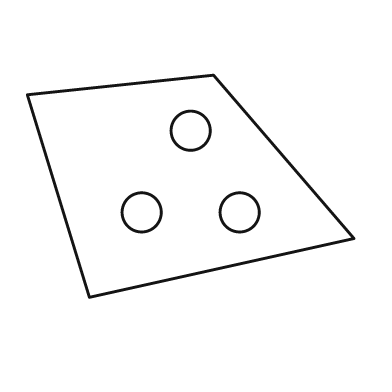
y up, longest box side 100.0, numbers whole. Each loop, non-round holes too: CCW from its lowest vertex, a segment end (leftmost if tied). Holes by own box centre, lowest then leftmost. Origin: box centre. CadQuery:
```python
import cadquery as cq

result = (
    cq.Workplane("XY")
    .moveTo(-31.0, -34.0)
    .lineTo(50.0, -16.0)
    .lineTo(7.0, 34.0)
    .lineTo(-50.0, 28.0)
    .close()
    .moveTo(-15.0, -8.0)
    .circle(6.0)
    .moveTo(15.0, -8.0)
    .circle(6.0)
    .moveTo(0.0, 17.0)
    .circle(6.0)
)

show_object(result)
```